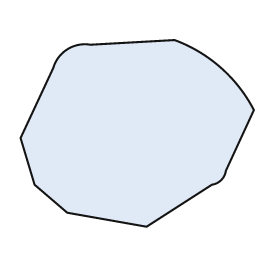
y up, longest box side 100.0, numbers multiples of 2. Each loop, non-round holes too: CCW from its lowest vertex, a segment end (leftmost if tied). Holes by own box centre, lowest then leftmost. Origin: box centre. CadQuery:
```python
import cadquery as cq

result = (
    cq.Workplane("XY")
    .moveTo(4.0, -40.0)
    .lineTo(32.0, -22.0)
    .threePointArc((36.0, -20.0), (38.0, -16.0))
    .lineTo(50.0, 10.0)
    .threePointArc((36.0, 28.0), (16.0, 40.0))
    .lineTo(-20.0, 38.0)
    .threePointArc((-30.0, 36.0), (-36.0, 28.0))
    .lineTo(-50.0, -2.0)
    .lineTo(-44.0, -22.0)
    .lineTo(-30.0, -34.0)
    .close()
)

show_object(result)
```